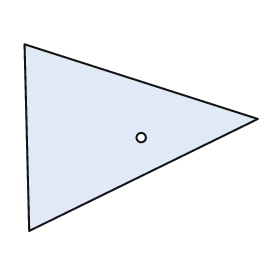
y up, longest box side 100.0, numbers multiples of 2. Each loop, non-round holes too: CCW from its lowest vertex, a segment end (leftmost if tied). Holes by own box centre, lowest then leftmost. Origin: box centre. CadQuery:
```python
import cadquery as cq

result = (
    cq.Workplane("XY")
    .moveTo(-48.0, -40.0)
    .lineTo(50.0, 8.0)
    .lineTo(-50.0, 40.0)
    .close()
    .moveTo(0.0, 0.0)
    .circle(2.0)
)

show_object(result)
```